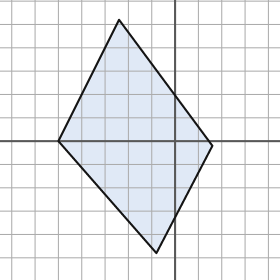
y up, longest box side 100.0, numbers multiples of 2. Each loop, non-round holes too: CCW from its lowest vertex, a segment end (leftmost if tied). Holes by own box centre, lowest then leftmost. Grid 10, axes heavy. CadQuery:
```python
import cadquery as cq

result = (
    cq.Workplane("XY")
    .moveTo(-8.0, -48.0)
    .lineTo(16.0, -2.0)
    .lineTo(-24.0, 52.0)
    .lineTo(-50.0, 0.0)
    .close()
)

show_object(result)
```